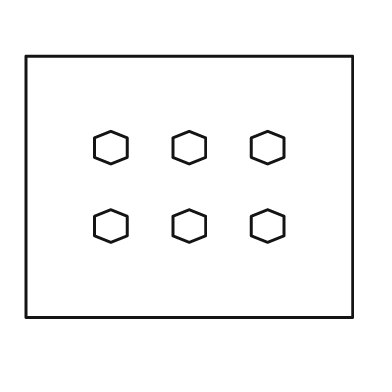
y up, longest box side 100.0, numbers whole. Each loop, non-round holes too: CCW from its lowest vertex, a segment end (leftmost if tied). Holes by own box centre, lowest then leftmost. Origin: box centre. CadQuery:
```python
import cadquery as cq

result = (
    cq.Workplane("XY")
    .moveTo(-50.0, -40.0)
    .lineTo(50.0, -40.0)
    .lineTo(50.0, 40.0)
    .lineTo(-50.0, 40.0)
    .close()
    .moveTo(-24.0, -17.0)
    .lineTo(-19.0, -15.0)
    .lineTo(-19.0, -9.0)
    .lineTo(-24.0, -7.0)
    .lineTo(-29.0, -9.0)
    .lineTo(-29.0, -15.0)
    .close()
    .moveTo(0.0, -17.0)
    .lineTo(5.0, -15.0)
    .lineTo(5.0, -9.0)
    .lineTo(0.0, -7.0)
    .lineTo(-5.0, -9.0)
    .lineTo(-5.0, -15.0)
    .close()
    .moveTo(24.0, -17.0)
    .lineTo(29.0, -15.0)
    .lineTo(29.0, -9.0)
    .lineTo(24.0, -7.0)
    .lineTo(19.0, -9.0)
    .lineTo(19.0, -15.0)
    .close()
    .moveTo(-24.0, 7.0)
    .lineTo(-19.0, 9.0)
    .lineTo(-19.0, 15.0)
    .lineTo(-24.0, 17.0)
    .lineTo(-29.0, 15.0)
    .lineTo(-29.0, 9.0)
    .close()
    .moveTo(0.0, 7.0)
    .lineTo(5.0, 9.0)
    .lineTo(5.0, 15.0)
    .lineTo(0.0, 17.0)
    .lineTo(-5.0, 15.0)
    .lineTo(-5.0, 9.0)
    .close()
    .moveTo(24.0, 7.0)
    .lineTo(29.0, 9.0)
    .lineTo(29.0, 15.0)
    .lineTo(24.0, 17.0)
    .lineTo(19.0, 15.0)
    .lineTo(19.0, 9.0)
    .close()
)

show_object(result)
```